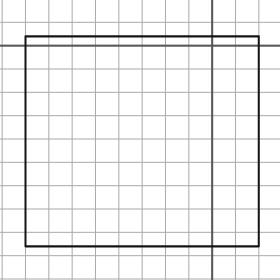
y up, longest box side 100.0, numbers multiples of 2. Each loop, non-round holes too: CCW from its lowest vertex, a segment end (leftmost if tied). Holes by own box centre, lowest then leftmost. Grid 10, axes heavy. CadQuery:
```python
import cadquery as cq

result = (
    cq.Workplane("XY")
    .moveTo(-80.0, -86.0)
    .lineTo(20.0, -86.0)
    .lineTo(20.0, 4.0)
    .lineTo(-80.0, 4.0)
    .close()
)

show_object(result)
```